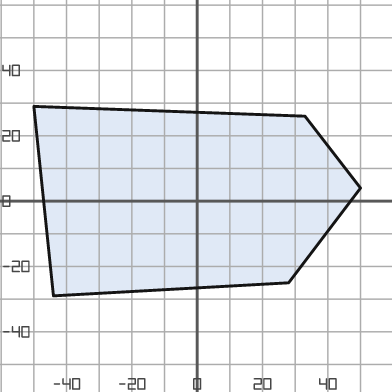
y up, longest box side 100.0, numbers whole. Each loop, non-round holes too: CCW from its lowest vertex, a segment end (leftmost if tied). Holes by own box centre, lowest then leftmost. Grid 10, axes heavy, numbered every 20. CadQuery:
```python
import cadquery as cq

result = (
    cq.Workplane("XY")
    .moveTo(-44.0, -29.0)
    .lineTo(28.0, -25.0)
    .lineTo(50.0, 4.0)
    .lineTo(33.0, 26.0)
    .lineTo(-50.0, 29.0)
    .close()
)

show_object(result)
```